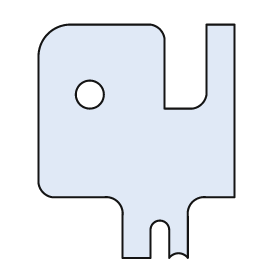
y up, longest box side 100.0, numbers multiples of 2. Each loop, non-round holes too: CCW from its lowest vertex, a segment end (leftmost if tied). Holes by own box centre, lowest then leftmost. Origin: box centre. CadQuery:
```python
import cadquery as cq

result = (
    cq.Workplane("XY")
    .moveTo(-6.0, -50.0)
    .lineTo(6.0, -50.0)
    .lineTo(6.0, -38.0)
    .threePointArc((10.0, -34.0), (14.0, -38.0))
    .lineTo(14.0, -50.0)
    .threePointArc((18.0, -48.0), (22.0, -50.0))
    .lineTo(22.0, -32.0)
    .threePointArc((24.0, -26.0), (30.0, -24.0))
    .lineTo(42.0, -24.0)
    .lineTo(42.0, 50.0)
    .lineTo(30.0, 50.0)
    .lineTo(30.0, 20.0)
    .threePointArc((28.0, 16.0), (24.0, 14.0))
    .lineTo(12.0, 14.0)
    .lineTo(12.0, 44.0)
    .threePointArc((10.0, 48.0), (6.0, 50.0))
    .lineTo(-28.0, 50.0)
    .threePointArc((-38.0, 46.0), (-42.0, 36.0))
    .lineTo(-42.0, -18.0)
    .threePointArc((-40.0, -22.0), (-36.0, -24.0))
    .lineTo(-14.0, -24.0)
    .threePointArc((-8.0, -26.0), (-6.0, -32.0))
    .close()
    .moveTo(-20.0, 20.0)
    .circle(6.0)
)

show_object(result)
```